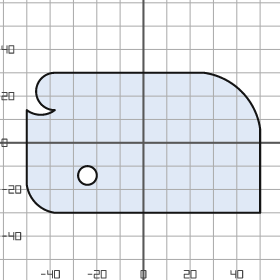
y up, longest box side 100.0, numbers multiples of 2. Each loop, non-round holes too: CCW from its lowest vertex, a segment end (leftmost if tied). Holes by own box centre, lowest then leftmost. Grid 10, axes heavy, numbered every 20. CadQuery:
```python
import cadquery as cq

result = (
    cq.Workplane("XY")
    .moveTo(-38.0, -30.0)
    .lineTo(50.0, -30.0)
    .lineTo(50.0, 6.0)
    .threePointArc((42.0, 22.0), (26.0, 30.0))
    .lineTo(-38.0, 30.0)
    .threePointArc((-46.0, 22.0), (-38.0, 14.0))
    .threePointArc((-44.0, 12.0), (-50.0, 14.0))
    .lineTo(-50.0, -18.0)
    .threePointArc((-46.0, -26.0), (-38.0, -30.0))
    .close()
    .moveTo(-24.0, -14.0)
    .circle(4.0)
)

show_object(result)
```